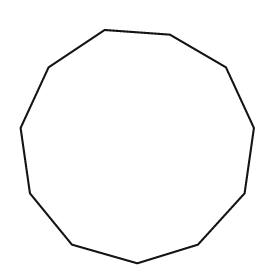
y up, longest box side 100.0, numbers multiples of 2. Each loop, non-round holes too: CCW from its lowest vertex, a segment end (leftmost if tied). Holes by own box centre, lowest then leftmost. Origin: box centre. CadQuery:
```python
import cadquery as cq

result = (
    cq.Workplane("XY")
    .moveTo(0.0, -50.0)
    .lineTo(26.0, -42.0)
    .lineTo(46.0, -20.0)
    .lineTo(50.0, 8.0)
    .lineTo(38.0, 34.0)
    .lineTo(14.0, 48.0)
    .lineTo(-14.0, 50.0)
    .lineTo(-38.0, 34.0)
    .lineTo(-50.0, 8.0)
    .lineTo(-46.0, -20.0)
    .lineTo(-28.0, -42.0)
    .close()
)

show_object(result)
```